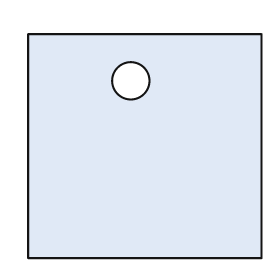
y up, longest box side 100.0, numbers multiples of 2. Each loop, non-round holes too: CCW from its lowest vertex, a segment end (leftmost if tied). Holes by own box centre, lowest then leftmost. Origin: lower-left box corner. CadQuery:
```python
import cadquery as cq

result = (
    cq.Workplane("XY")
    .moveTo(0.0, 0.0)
    .lineTo(100.0, 0.0)
    .lineTo(100.0, 96.0)
    .lineTo(0.0, 96.0)
    .close()
    .moveTo(44.0, 76.0)
    .circle(8.0)
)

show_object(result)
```